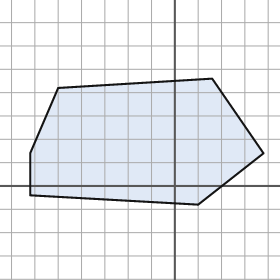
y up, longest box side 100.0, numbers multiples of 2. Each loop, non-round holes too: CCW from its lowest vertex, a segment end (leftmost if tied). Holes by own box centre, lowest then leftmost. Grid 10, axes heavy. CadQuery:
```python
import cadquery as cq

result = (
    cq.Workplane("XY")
    .moveTo(10.0, -8.0)
    .lineTo(38.0, 14.0)
    .lineTo(16.0, 46.0)
    .lineTo(-50.0, 42.0)
    .lineTo(-62.0, 14.0)
    .lineTo(-62.0, -4.0)
    .close()
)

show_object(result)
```